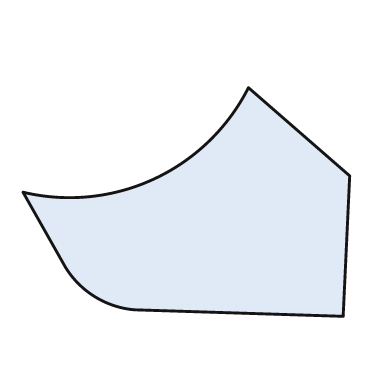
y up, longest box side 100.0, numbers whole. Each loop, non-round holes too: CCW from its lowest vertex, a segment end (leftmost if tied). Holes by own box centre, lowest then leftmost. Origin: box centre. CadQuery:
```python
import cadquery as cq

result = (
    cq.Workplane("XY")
    .moveTo(48.0, -35.0)
    .lineTo(50.0, 8.0)
    .lineTo(19.0, 35.0)
    .threePointArc((-10.0, 7.0), (-50.0, 3.0))
    .lineTo(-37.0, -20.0)
    .threePointArc((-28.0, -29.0), (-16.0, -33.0))
    .close()
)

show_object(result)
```